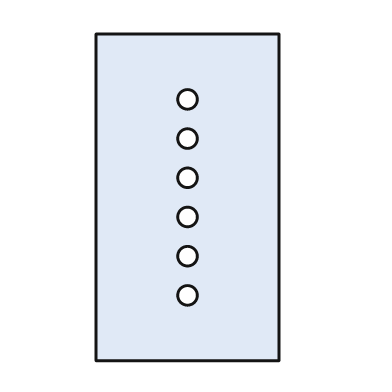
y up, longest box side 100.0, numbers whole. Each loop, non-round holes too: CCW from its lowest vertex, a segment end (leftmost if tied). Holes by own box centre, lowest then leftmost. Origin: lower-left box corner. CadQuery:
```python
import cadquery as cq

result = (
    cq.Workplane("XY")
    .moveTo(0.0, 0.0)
    .lineTo(56.0, 0.0)
    .lineTo(56.0, 100.0)
    .lineTo(0.0, 100.0)
    .close()
    .moveTo(28.0, 20.0)
    .circle(3.0)
    .moveTo(28.0, 32.0)
    .circle(3.0)
    .moveTo(28.0, 44.0)
    .circle(3.0)
    .moveTo(28.0, 56.0)
    .circle(3.0)
    .moveTo(28.0, 68.0)
    .circle(3.0)
    .moveTo(28.0, 80.0)
    .circle(3.0)
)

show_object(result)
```